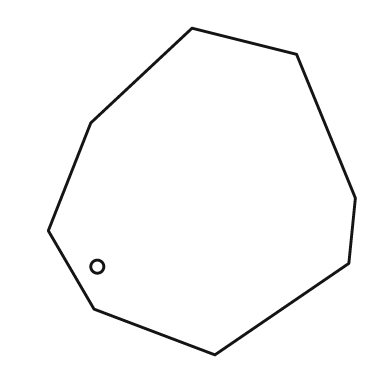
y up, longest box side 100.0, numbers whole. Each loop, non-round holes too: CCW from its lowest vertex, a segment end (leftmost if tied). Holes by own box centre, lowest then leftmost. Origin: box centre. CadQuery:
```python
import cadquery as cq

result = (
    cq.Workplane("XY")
    .moveTo(4.0, -50.0)
    .lineTo(45.0, -22.0)
    .lineTo(47.0, -2.0)
    .lineTo(29.0, 42.0)
    .lineTo(-3.0, 50.0)
    .lineTo(-34.0, 21.0)
    .lineTo(-47.0, -12.0)
    .lineTo(-33.0, -36.0)
    .close()
    .moveTo(-32.0, -23.0)
    .circle(2.0)
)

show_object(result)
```